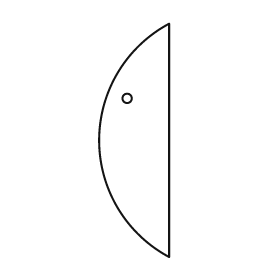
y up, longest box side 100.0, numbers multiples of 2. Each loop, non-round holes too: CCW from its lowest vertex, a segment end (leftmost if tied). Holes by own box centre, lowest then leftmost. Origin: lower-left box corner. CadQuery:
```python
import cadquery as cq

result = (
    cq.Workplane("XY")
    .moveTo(30.0, 0.0)
    .lineTo(30.0, 100.0)
    .threePointArc((0.0, 50.0), (30.0, 0.0))
    .close()
    .moveTo(12.0, 68.0)
    .circle(2.0)
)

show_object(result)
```